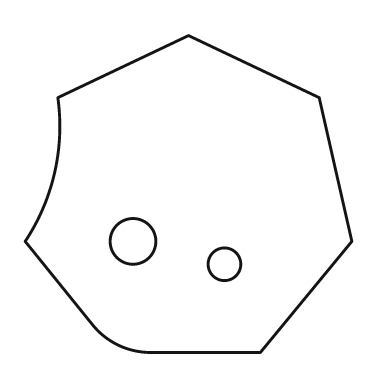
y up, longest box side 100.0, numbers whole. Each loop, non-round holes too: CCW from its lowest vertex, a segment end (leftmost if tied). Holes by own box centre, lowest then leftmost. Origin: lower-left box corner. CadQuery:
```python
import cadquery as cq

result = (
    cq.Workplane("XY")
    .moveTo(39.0, 0.0)
    .lineTo(72.0, 0.0)
    .lineTo(100.0, 34.0)
    .lineTo(90.0, 78.0)
    .lineTo(50.0, 97.0)
    .lineTo(10.0, 78.0)
    .threePointArc((9.0, 55.0), (0.0, 34.0))
    .lineTo(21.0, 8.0)
    .threePointArc((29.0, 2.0), (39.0, 0.0))
    .close()
    .moveTo(61.0, 27.0)
    .circle(5.0)
    .moveTo(33.0, 34.0)
    .circle(7.0)
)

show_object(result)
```